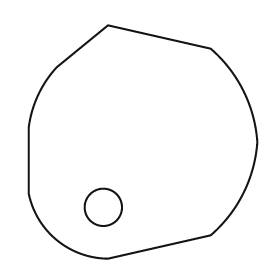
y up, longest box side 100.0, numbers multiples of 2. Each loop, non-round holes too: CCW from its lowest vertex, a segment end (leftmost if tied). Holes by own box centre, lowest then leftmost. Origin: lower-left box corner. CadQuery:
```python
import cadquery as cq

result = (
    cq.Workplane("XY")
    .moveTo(34.0, 0.0)
    .lineTo(78.0, 10.0)
    .threePointArc((92.0, 28.0), (98.0, 50.0))
    .threePointArc((92.0, 72.0), (78.0, 90.0))
    .lineTo(34.0, 100.0)
    .lineTo(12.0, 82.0)
    .threePointArc((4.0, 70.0), (0.0, 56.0))
    .lineTo(0.0, 28.0)
    .threePointArc((12.0, 8.0), (34.0, 0.0))
    .close()
    .moveTo(32.0, 22.0)
    .circle(8.0)
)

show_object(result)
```